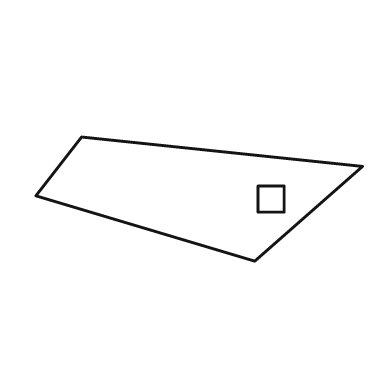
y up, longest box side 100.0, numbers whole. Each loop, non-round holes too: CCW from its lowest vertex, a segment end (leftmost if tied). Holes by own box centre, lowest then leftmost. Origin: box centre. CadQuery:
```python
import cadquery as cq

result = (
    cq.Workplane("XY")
    .moveTo(17.0, -19.0)
    .lineTo(50.0, 10.0)
    .lineTo(-36.0, 19.0)
    .lineTo(-50.0, 1.0)
    .close()
    .moveTo(18.0, -4.0)
    .lineTo(26.0, -4.0)
    .lineTo(26.0, 4.0)
    .lineTo(18.0, 4.0)
    .close()
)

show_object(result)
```